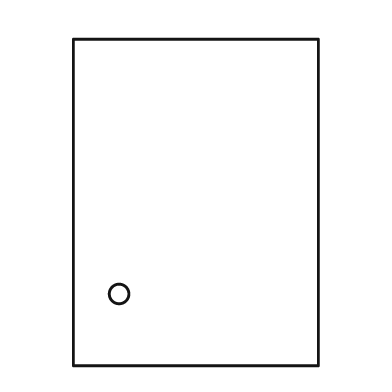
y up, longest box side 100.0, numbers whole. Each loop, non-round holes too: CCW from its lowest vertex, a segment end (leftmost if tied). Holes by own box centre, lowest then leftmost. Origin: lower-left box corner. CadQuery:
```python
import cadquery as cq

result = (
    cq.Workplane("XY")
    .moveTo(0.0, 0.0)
    .lineTo(75.0, 0.0)
    .lineTo(75.0, 100.0)
    .lineTo(0.0, 100.0)
    .close()
    .moveTo(14.0, 22.0)
    .circle(3.0)
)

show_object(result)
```